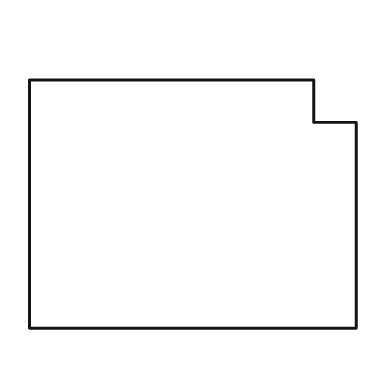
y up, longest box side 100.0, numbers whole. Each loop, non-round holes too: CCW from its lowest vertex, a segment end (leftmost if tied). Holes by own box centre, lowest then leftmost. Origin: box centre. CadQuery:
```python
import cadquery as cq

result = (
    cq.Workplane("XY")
    .moveTo(-50.0, -38.0)
    .lineTo(50.0, -38.0)
    .lineTo(50.0, 25.0)
    .lineTo(37.0, 25.0)
    .lineTo(37.0, 38.0)
    .lineTo(-50.0, 38.0)
    .close()
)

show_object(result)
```